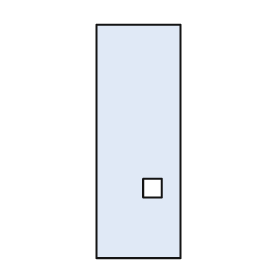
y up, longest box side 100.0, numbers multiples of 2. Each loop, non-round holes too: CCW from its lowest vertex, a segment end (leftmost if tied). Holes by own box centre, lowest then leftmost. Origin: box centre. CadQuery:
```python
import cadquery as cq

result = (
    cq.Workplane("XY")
    .moveTo(-18.0, -50.0)
    .lineTo(18.0, -50.0)
    .lineTo(18.0, 50.0)
    .lineTo(-18.0, 50.0)
    .close()
    .moveTo(2.0, -24.0)
    .lineTo(10.0, -24.0)
    .lineTo(10.0, -16.0)
    .lineTo(2.0, -16.0)
    .close()
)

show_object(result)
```